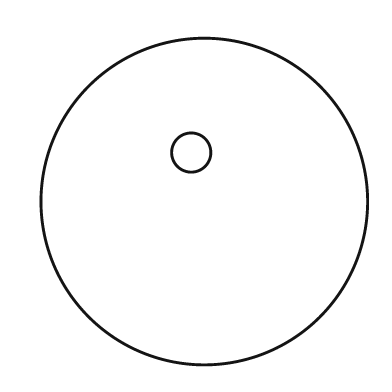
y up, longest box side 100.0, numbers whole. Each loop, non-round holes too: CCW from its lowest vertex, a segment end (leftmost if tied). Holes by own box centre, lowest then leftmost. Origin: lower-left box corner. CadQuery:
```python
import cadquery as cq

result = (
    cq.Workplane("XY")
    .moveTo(50.0, 50.0)
    .circle(50.0)
    .moveTo(46.0, 65.0)
    .circle(6.0)
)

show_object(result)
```